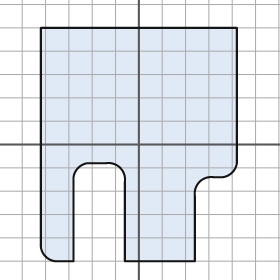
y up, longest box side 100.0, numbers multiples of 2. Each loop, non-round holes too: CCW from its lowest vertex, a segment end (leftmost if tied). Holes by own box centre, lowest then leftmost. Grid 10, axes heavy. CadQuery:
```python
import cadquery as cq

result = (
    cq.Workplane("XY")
    .moveTo(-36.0, -50.0)
    .lineTo(-28.0, -50.0)
    .lineTo(-28.0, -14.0)
    .threePointArc((-26.0, -10.0), (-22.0, -8.0))
    .lineTo(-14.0, -8.0)
    .threePointArc((-8.0, -10.0), (-6.0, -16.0))
    .lineTo(-6.0, -50.0)
    .lineTo(24.0, -50.0)
    .lineTo(24.0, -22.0)
    .threePointArc((26.0, -16.0), (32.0, -14.0))
    .lineTo(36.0, -14.0)
    .threePointArc((40.0, -12.0), (42.0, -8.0))
    .lineTo(42.0, 50.0)
    .lineTo(-42.0, 50.0)
    .lineTo(-42.0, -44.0)
    .threePointArc((-40.0, -48.0), (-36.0, -50.0))
    .close()
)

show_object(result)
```